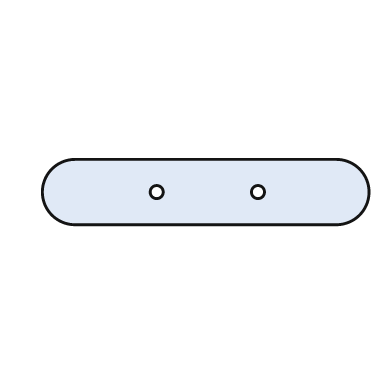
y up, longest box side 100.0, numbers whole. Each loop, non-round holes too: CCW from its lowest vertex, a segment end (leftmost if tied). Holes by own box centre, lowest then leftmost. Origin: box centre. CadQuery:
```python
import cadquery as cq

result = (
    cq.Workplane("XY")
    .moveTo(-40.0, -10.0)
    .lineTo(40.0, -10.0)
    .threePointArc((50.0, 0.0), (40.0, 10.0))
    .lineTo(-40.0, 10.0)
    .threePointArc((-50.0, 0.0), (-40.0, -10.0))
    .close()
    .moveTo(-15.0, 0.0)
    .circle(2.0)
    .moveTo(16.0, 0.0)
    .circle(2.0)
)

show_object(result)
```